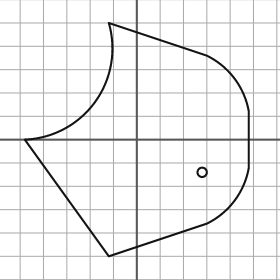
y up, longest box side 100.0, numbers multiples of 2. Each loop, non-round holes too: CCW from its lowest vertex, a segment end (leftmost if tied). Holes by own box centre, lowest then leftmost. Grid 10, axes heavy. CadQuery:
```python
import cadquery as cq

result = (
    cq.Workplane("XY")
    .moveTo(-12.0, -50.0)
    .lineTo(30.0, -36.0)
    .threePointArc((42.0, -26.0), (48.0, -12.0))
    .lineTo(48.0, 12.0)
    .threePointArc((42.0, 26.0), (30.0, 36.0))
    .lineTo(-12.0, 50.0)
    .threePointArc((-18.0, 16.0), (-48.0, 0.0))
    .close()
    .moveTo(28.0, -14.0)
    .circle(2.0)
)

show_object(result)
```